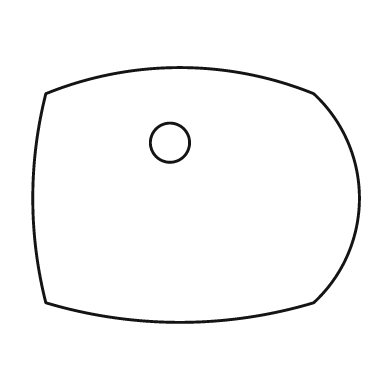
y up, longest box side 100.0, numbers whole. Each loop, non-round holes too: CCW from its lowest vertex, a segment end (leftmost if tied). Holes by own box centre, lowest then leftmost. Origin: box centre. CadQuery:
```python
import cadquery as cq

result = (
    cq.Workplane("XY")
    .moveTo(-46.0, -33.0)
    .threePointArc((-5.0, -39.0), (36.0, -33.0))
    .threePointArc((50.0, -1.0), (36.0, 31.0))
    .threePointArc((-5.0, 39.0), (-46.0, 31.0))
    .threePointArc((-50.0, -1.0), (-46.0, -33.0))
    .close()
    .moveTo(-8.0, 16.0)
    .circle(6.0)
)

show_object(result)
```